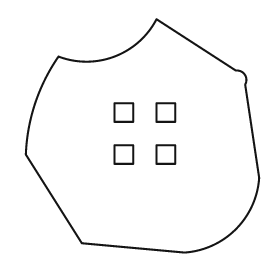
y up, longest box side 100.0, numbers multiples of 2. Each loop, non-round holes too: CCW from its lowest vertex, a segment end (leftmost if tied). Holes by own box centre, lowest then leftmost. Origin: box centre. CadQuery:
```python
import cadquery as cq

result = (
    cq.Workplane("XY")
    .moveTo(18.0, -50.0)
    .threePointArc((40.0, -40.0), (50.0, -18.0))
    .lineTo(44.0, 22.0)
    .threePointArc((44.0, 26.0), (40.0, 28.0))
    .lineTo(6.0, 50.0)
    .threePointArc((-12.0, 34.0), (-36.0, 34.0))
    .threePointArc((-46.0, 14.0), (-50.0, -8.0))
    .lineTo(-26.0, -46.0)
    .close()
    .moveTo(-12.0, -12.0)
    .lineTo(-4.0, -12.0)
    .lineTo(-4.0, -4.0)
    .lineTo(-12.0, -4.0)
    .close()
    .moveTo(6.0, -12.0)
    .lineTo(14.0, -12.0)
    .lineTo(14.0, -4.0)
    .lineTo(6.0, -4.0)
    .close()
    .moveTo(-12.0, 6.0)
    .lineTo(-4.0, 6.0)
    .lineTo(-4.0, 14.0)
    .lineTo(-12.0, 14.0)
    .close()
    .moveTo(6.0, 6.0)
    .lineTo(14.0, 6.0)
    .lineTo(14.0, 14.0)
    .lineTo(6.0, 14.0)
    .close()
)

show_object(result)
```